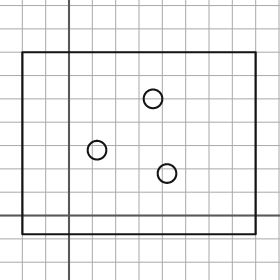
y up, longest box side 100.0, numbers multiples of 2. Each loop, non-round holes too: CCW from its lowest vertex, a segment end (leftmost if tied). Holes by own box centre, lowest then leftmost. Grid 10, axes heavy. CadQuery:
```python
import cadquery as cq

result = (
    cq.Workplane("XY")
    .moveTo(-20.0, -8.0)
    .lineTo(80.0, -8.0)
    .lineTo(80.0, 70.0)
    .lineTo(-20.0, 70.0)
    .close()
    .moveTo(42.0, 18.0)
    .circle(4.0)
    .moveTo(12.0, 28.0)
    .circle(4.0)
    .moveTo(36.0, 50.0)
    .circle(4.0)
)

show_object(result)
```